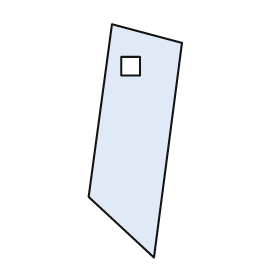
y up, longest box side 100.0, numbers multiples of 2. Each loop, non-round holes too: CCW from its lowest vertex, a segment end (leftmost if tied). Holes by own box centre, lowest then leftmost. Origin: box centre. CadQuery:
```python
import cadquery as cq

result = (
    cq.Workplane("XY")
    .moveTo(8.0, -50.0)
    .lineTo(20.0, 42.0)
    .lineTo(-10.0, 50.0)
    .lineTo(-20.0, -24.0)
    .close()
    .moveTo(-6.0, 28.0)
    .lineTo(2.0, 28.0)
    .lineTo(2.0, 36.0)
    .lineTo(-6.0, 36.0)
    .close()
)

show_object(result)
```